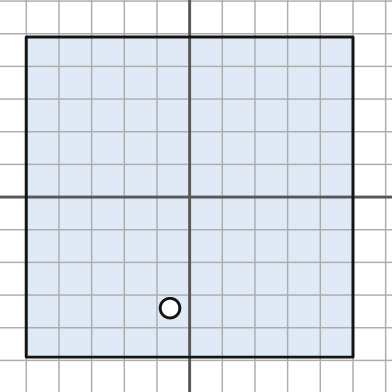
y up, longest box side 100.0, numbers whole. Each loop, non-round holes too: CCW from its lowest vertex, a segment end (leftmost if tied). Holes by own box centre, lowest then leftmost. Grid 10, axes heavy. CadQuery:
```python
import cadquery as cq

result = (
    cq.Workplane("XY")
    .moveTo(-50.0, -49.0)
    .lineTo(50.0, -49.0)
    .lineTo(50.0, 49.0)
    .lineTo(-50.0, 49.0)
    .close()
    .moveTo(-6.0, -34.0)
    .circle(3.0)
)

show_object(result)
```